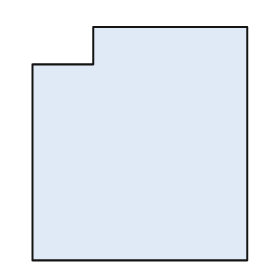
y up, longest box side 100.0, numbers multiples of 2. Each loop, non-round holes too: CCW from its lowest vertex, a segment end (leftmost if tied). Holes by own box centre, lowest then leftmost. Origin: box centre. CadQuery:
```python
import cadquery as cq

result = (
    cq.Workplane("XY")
    .moveTo(-46.0, -50.0)
    .lineTo(46.0, -50.0)
    .lineTo(46.0, 50.0)
    .lineTo(-20.0, 50.0)
    .lineTo(-20.0, 34.0)
    .lineTo(-46.0, 34.0)
    .close()
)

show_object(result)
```